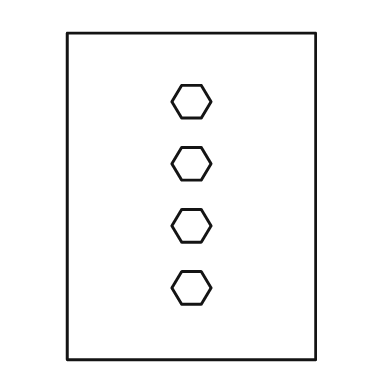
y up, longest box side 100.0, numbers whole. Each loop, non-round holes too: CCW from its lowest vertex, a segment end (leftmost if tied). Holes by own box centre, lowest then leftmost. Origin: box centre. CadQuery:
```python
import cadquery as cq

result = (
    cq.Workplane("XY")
    .moveTo(-38.0, -50.0)
    .lineTo(38.0, -50.0)
    .lineTo(38.0, 50.0)
    .lineTo(-38.0, 50.0)
    .close()
    .moveTo(-3.0, -33.0)
    .lineTo(3.0, -33.0)
    .lineTo(6.0, -28.0)
    .lineTo(3.0, -23.0)
    .lineTo(-3.0, -23.0)
    .lineTo(-6.0, -28.0)
    .close()
    .moveTo(-3.0, -14.0)
    .lineTo(3.0, -14.0)
    .lineTo(6.0, -9.0)
    .lineTo(3.0, -4.0)
    .lineTo(-3.0, -4.0)
    .lineTo(-6.0, -9.0)
    .close()
    .moveTo(-3.0, 5.0)
    .lineTo(3.0, 5.0)
    .lineTo(6.0, 10.0)
    .lineTo(3.0, 15.0)
    .lineTo(-3.0, 15.0)
    .lineTo(-6.0, 10.0)
    .close()
    .moveTo(-3.0, 24.0)
    .lineTo(3.0, 24.0)
    .lineTo(6.0, 29.0)
    .lineTo(3.0, 34.0)
    .lineTo(-3.0, 34.0)
    .lineTo(-6.0, 29.0)
    .close()
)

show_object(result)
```